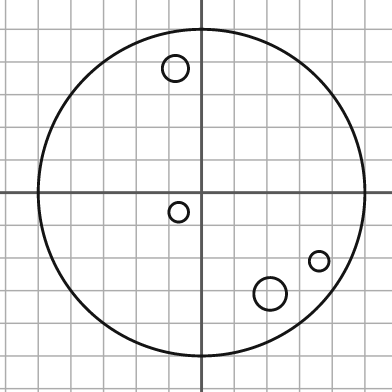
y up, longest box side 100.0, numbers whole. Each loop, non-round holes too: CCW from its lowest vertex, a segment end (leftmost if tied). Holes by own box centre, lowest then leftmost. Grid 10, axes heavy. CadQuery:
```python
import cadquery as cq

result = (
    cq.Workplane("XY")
    .moveTo(0.0, 0.0)
    .circle(50.0)
    .moveTo(21.0, -31.0)
    .circle(5.0)
    .moveTo(36.0, -21.0)
    .circle(3.0)
    .moveTo(-7.0, -6.0)
    .circle(3.0)
    .moveTo(-8.0, 38.0)
    .circle(4.0)
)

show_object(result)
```